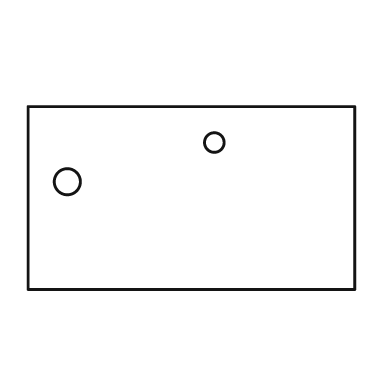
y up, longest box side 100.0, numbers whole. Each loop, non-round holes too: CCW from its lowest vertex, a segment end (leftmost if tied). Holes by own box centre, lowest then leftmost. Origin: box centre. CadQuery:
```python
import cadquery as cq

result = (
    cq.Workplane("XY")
    .moveTo(-50.0, -28.0)
    .lineTo(50.0, -28.0)
    .lineTo(50.0, 28.0)
    .lineTo(-50.0, 28.0)
    .close()
    .moveTo(-38.0, 5.0)
    .circle(4.0)
    .moveTo(7.0, 17.0)
    .circle(3.0)
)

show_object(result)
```